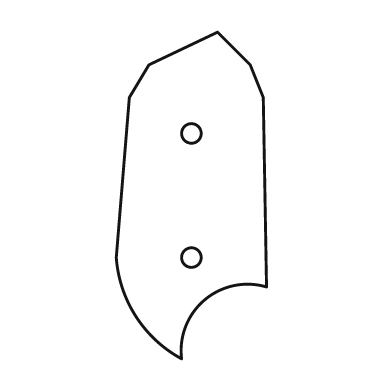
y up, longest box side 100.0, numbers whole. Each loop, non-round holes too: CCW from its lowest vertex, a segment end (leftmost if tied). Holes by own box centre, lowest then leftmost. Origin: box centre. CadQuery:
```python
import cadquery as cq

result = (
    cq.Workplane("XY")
    .moveTo(-3.0, -50.0)
    .threePointArc((4.0, -32.0), (23.0, -28.0))
    .lineTo(22.0, 30.0)
    .lineTo(18.0, 40.0)
    .lineTo(8.0, 50.0)
    .lineTo(-13.0, 40.0)
    .lineTo(-19.0, 30.0)
    .lineTo(-23.0, -19.0)
    .threePointArc((-17.0, -37.0), (-3.0, -50.0))
    .close()
    .moveTo(0.0, -19.0)
    .circle(3.0)
    .moveTo(0.0, 19.0)
    .circle(3.0)
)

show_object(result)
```